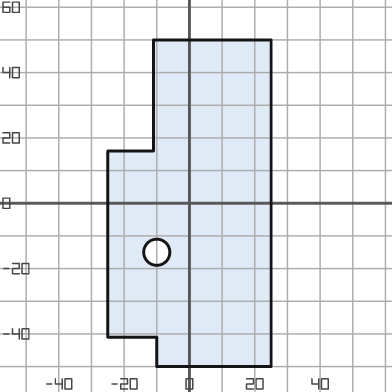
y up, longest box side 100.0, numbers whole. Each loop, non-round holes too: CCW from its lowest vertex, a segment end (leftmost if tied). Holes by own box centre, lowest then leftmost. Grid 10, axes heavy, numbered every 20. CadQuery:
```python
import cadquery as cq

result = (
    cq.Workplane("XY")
    .moveTo(-10.0, -50.0)
    .lineTo(25.0, -50.0)
    .lineTo(25.0, 50.0)
    .lineTo(-11.0, 50.0)
    .lineTo(-11.0, 16.0)
    .lineTo(-25.0, 16.0)
    .lineTo(-25.0, -41.0)
    .lineTo(-10.0, -41.0)
    .close()
    .moveTo(-10.0, -15.0)
    .circle(4.0)
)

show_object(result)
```